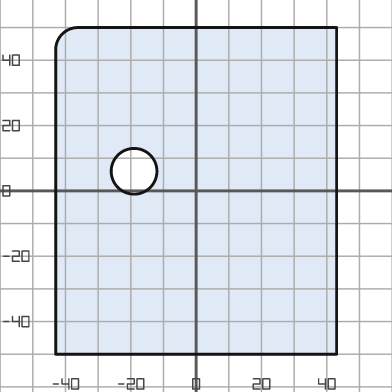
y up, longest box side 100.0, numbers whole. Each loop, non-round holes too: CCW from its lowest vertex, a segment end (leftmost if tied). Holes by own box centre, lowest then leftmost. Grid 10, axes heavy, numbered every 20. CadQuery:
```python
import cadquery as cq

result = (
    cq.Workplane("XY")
    .moveTo(-43.0, -50.0)
    .lineTo(43.0, -50.0)
    .lineTo(43.0, 50.0)
    .lineTo(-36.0, 50.0)
    .threePointArc((-41.0, 48.0), (-43.0, 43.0))
    .close()
    .moveTo(-19.0, 6.0)
    .circle(7.0)
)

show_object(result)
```